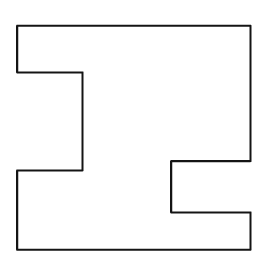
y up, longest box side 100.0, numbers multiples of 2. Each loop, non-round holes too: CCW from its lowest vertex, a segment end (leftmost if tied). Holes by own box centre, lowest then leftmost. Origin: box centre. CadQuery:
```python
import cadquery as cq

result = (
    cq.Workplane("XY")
    .moveTo(-50.0, -48.0)
    .lineTo(50.0, -48.0)
    .lineTo(50.0, -32.0)
    .lineTo(16.0, -32.0)
    .lineTo(16.0, -10.0)
    .lineTo(50.0, -10.0)
    .lineTo(50.0, 48.0)
    .lineTo(-50.0, 48.0)
    .lineTo(-50.0, 28.0)
    .lineTo(-22.0, 28.0)
    .lineTo(-22.0, -14.0)
    .lineTo(-50.0, -14.0)
    .close()
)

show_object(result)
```